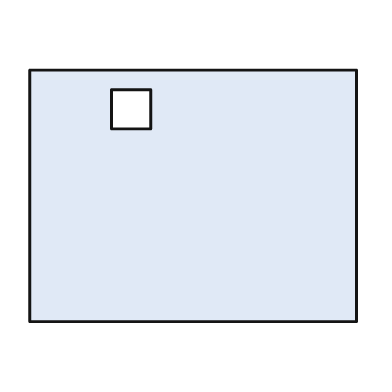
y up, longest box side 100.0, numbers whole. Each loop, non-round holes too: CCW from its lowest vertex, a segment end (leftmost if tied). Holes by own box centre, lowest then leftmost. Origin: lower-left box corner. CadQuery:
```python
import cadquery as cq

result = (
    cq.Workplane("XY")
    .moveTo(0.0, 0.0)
    .lineTo(100.0, 0.0)
    .lineTo(100.0, 77.0)
    .lineTo(0.0, 77.0)
    .close()
    .moveTo(25.0, 59.0)
    .lineTo(37.0, 59.0)
    .lineTo(37.0, 71.0)
    .lineTo(25.0, 71.0)
    .close()
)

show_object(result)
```